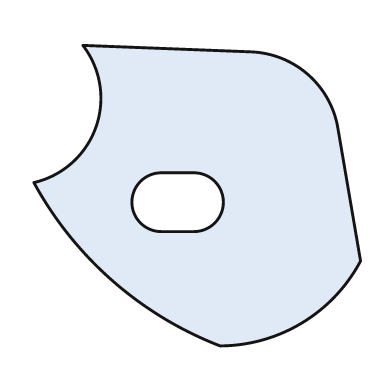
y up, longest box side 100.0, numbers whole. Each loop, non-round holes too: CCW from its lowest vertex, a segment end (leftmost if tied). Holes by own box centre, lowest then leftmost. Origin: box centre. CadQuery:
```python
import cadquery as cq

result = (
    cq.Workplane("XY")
    .moveTo(7.0, -46.0)
    .threePointArc((32.0, -39.0), (50.0, -20.0))
    .lineTo(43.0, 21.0)
    .threePointArc((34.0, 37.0), (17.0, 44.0))
    .lineTo(-35.0, 46.0)
    .threePointArc((-31.0, 21.0), (-50.0, 4.0))
    .threePointArc((-26.0, -26.0), (7.0, -46.0))
    .close()
    .moveTo(-11.0, -11.0)
    .lineTo(-1.0, -11.0)
    .threePointArc((8.0, -2.0), (-1.0, 7.0))
    .lineTo(-11.0, 7.0)
    .threePointArc((-20.0, -2.0), (-11.0, -11.0))
    .close()
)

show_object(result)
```